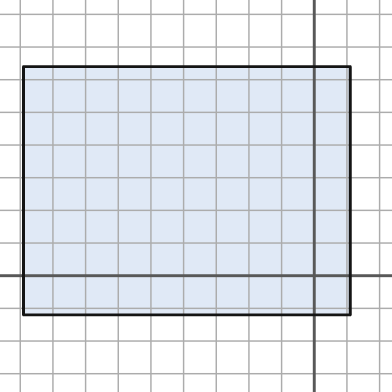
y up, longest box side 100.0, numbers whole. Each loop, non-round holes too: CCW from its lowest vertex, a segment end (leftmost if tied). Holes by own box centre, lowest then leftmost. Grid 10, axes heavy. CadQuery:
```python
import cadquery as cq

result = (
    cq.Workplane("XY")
    .moveTo(-89.0, -12.0)
    .lineTo(11.0, -12.0)
    .lineTo(11.0, 64.0)
    .lineTo(-89.0, 64.0)
    .close()
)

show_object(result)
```